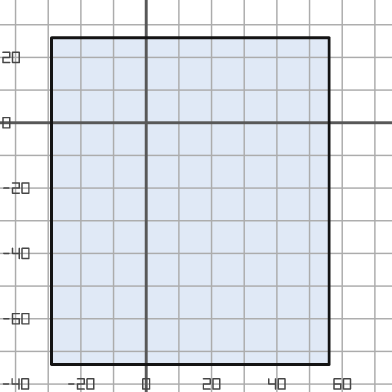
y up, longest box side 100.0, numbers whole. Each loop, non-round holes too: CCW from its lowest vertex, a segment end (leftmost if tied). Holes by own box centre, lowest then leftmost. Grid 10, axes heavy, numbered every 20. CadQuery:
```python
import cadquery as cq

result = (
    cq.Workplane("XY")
    .moveTo(-29.0, -74.0)
    .lineTo(56.0, -74.0)
    .lineTo(56.0, 26.0)
    .lineTo(-29.0, 26.0)
    .close()
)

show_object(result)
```